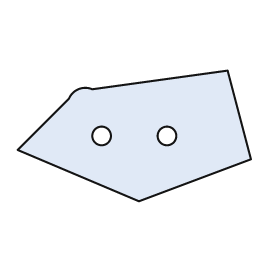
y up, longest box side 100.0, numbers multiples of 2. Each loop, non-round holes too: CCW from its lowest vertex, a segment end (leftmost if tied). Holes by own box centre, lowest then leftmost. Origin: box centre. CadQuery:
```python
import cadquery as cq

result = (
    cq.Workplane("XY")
    .moveTo(2.0, -28.0)
    .lineTo(50.0, -10.0)
    .lineTo(40.0, 28.0)
    .lineTo(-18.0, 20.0)
    .threePointArc((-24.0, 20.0), (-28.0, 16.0))
    .lineTo(-50.0, -6.0)
    .close()
    .moveTo(-14.0, 0.0)
    .circle(4.0)
    .moveTo(14.0, 0.0)
    .circle(4.0)
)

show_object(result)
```